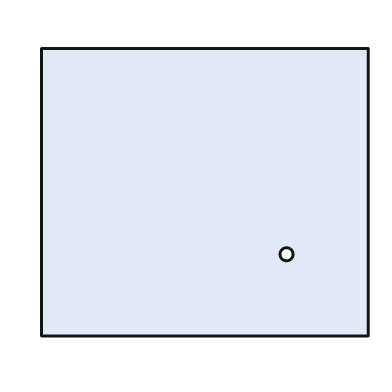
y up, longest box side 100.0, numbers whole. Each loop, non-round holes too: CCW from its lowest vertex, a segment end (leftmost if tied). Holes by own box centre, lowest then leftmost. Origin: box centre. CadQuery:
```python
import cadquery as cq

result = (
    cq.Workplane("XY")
    .moveTo(-50.0, -44.0)
    .lineTo(50.0, -44.0)
    .lineTo(50.0, 44.0)
    .lineTo(-50.0, 44.0)
    .close()
    .moveTo(25.0, -19.0)
    .circle(2.0)
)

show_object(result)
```